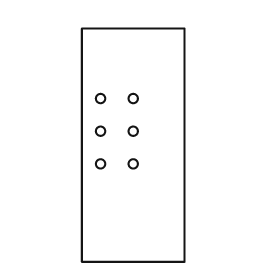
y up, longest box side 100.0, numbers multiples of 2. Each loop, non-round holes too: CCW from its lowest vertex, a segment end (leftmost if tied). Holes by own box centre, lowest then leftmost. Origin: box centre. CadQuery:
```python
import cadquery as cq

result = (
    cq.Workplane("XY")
    .moveTo(-22.0, -50.0)
    .lineTo(22.0, -50.0)
    .lineTo(22.0, 50.0)
    .lineTo(-22.0, 50.0)
    .close()
    .moveTo(-14.0, -8.0)
    .circle(2.0)
    .moveTo(0.0, -8.0)
    .circle(2.0)
    .moveTo(-14.0, 6.0)
    .circle(2.0)
    .moveTo(0.0, 6.0)
    .circle(2.0)
    .moveTo(-14.0, 20.0)
    .circle(2.0)
    .moveTo(0.0, 20.0)
    .circle(2.0)
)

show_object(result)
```